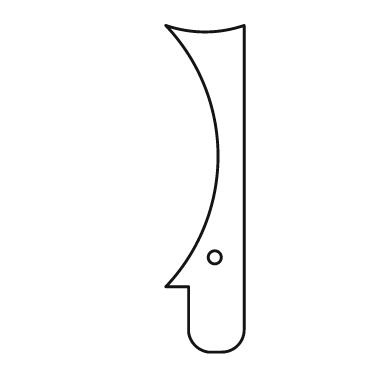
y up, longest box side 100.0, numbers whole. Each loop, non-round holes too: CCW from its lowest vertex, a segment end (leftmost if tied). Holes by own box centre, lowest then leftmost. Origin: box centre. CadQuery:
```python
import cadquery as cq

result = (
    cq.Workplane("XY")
    .moveTo(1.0, -50.0)
    .lineTo(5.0, -50.0)
    .threePointArc((10.0, -48.0), (12.0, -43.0))
    .lineTo(12.0, 50.0)
    .threePointArc((0.0, 48.0), (-12.0, 50.0))
    .threePointArc((4.0, 10.0), (-12.0, -30.0))
    .lineTo(-5.0, -30.0)
    .lineTo(-5.0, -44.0)
    .threePointArc((-3.0, -48.0), (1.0, -50.0))
    .close()
    .moveTo(3.0, -21.0)
    .circle(2.0)
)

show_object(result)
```